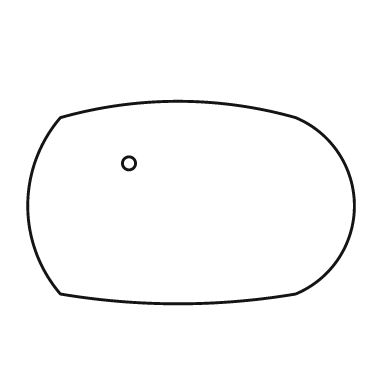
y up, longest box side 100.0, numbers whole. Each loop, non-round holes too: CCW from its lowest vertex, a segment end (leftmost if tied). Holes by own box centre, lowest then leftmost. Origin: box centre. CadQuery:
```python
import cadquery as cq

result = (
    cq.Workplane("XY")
    .moveTo(-40.0, -28.0)
    .threePointArc((-4.0, -31.0), (32.0, -28.0))
    .threePointArc((50.0, -1.0), (32.0, 26.0))
    .threePointArc((-4.0, 31.0), (-40.0, 26.0))
    .threePointArc((-50.0, -1.0), (-40.0, -28.0))
    .close()
    .moveTo(-19.0, 12.0)
    .circle(2.0)
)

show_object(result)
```